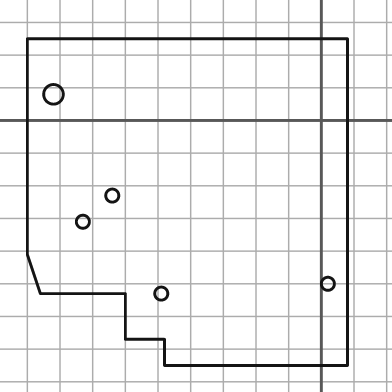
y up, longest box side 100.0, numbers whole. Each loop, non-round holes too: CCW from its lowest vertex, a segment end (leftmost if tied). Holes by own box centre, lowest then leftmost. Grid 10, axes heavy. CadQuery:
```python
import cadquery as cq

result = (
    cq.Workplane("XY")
    .moveTo(-48.0, -75.0)
    .lineTo(8.0, -75.0)
    .lineTo(8.0, 25.0)
    .lineTo(-90.0, 25.0)
    .lineTo(-90.0, -41.0)
    .lineTo(-86.0, -53.0)
    .lineTo(-60.0, -53.0)
    .lineTo(-60.0, -67.0)
    .lineTo(-48.0, -67.0)
    .close()
    .moveTo(-49.0, -53.0)
    .circle(2.0)
    .moveTo(2.0, -50.0)
    .circle(2.0)
    .moveTo(-73.0, -31.0)
    .circle(2.0)
    .moveTo(-64.0, -23.0)
    .circle(2.0)
    .moveTo(-82.0, 8.0)
    .circle(3.0)
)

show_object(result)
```